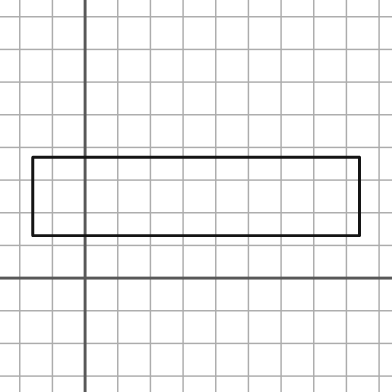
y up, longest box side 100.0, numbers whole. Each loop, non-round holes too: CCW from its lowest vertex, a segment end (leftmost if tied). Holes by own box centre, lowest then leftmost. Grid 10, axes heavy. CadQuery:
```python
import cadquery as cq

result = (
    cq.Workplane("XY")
    .moveTo(-16.0, 13.0)
    .lineTo(84.0, 13.0)
    .lineTo(84.0, 37.0)
    .lineTo(-16.0, 37.0)
    .close()
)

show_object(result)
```